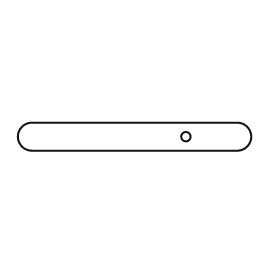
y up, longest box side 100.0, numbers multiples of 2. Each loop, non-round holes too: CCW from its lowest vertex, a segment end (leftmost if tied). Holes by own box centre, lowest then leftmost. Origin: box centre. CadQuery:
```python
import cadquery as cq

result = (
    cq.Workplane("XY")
    .moveTo(-44.0, -6.0)
    .lineTo(44.0, -6.0)
    .threePointArc((50.0, 0.0), (44.0, 6.0))
    .lineTo(-44.0, 6.0)
    .threePointArc((-50.0, 0.0), (-44.0, -6.0))
    .close()
    .moveTo(22.0, 0.0)
    .circle(2.0)
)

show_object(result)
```